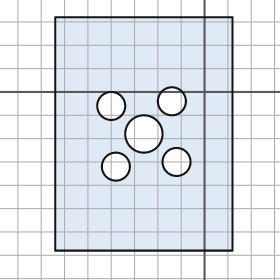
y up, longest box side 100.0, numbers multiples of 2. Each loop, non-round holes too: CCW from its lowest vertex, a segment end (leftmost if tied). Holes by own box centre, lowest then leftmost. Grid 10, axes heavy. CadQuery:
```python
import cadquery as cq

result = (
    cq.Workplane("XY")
    .moveTo(-64.0, -68.0)
    .lineTo(12.0, -68.0)
    .lineTo(12.0, 32.0)
    .lineTo(-64.0, 32.0)
    .close()
    .moveTo(-38.0, -32.0)
    .circle(6.0)
    .moveTo(-12.0, -30.0)
    .circle(6.0)
    .moveTo(-26.0, -18.0)
    .circle(8.0)
    .moveTo(-40.0, -6.0)
    .circle(6.0)
    .moveTo(-14.0, -4.0)
    .circle(6.0)
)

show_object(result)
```